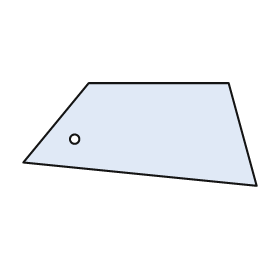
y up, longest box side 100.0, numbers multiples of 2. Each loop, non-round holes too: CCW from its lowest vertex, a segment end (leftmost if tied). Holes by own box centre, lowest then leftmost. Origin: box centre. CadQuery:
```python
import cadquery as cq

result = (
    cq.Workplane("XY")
    .moveTo(50.0, -22.0)
    .lineTo(38.0, 22.0)
    .lineTo(-22.0, 22.0)
    .lineTo(-50.0, -12.0)
    .close()
    .moveTo(-28.0, -2.0)
    .circle(2.0)
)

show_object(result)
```